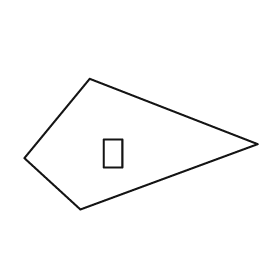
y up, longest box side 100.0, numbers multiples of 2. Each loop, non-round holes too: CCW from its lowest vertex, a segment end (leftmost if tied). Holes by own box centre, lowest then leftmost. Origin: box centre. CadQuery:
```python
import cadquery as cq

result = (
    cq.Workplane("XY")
    .moveTo(-26.0, -28.0)
    .lineTo(50.0, 0.0)
    .lineTo(-22.0, 28.0)
    .lineTo(-50.0, -6.0)
    .close()
    .moveTo(-16.0, -10.0)
    .lineTo(-8.0, -10.0)
    .lineTo(-8.0, 2.0)
    .lineTo(-16.0, 2.0)
    .close()
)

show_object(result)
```